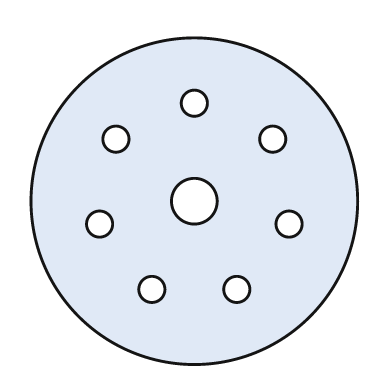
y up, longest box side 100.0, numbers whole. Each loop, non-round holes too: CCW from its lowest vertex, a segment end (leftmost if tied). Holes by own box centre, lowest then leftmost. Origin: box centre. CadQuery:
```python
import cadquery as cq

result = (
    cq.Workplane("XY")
    .moveTo(0.0, 0.0)
    .circle(50.0)
    .moveTo(-13.0, -27.0)
    .circle(4.0)
    .moveTo(13.0, -27.0)
    .circle(4.0)
    .moveTo(-29.0, -7.0)
    .circle(4.0)
    .moveTo(29.0, -7.0)
    .circle(4.0)
    .moveTo(0.0, 0.0)
    .circle(7.0)
    .moveTo(-24.0, 19.0)
    .circle(4.0)
    .moveTo(24.0, 19.0)
    .circle(4.0)
    .moveTo(0.0, 30.0)
    .circle(4.0)
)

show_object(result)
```